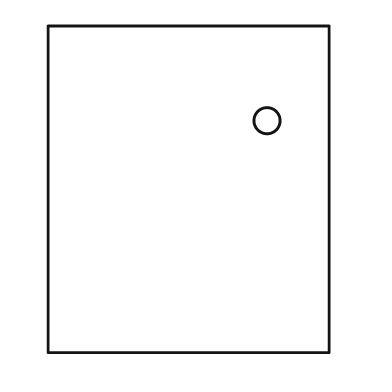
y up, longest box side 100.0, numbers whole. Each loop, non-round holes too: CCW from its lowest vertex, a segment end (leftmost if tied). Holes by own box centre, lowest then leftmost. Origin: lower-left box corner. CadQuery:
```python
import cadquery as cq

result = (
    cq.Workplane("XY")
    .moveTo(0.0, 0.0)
    .lineTo(86.0, 0.0)
    .lineTo(86.0, 100.0)
    .lineTo(0.0, 100.0)
    .close()
    .moveTo(67.0, 71.0)
    .circle(4.0)
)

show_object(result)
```